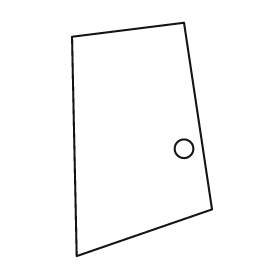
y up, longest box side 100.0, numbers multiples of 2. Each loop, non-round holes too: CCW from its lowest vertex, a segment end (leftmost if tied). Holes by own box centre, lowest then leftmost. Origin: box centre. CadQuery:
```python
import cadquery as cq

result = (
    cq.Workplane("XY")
    .moveTo(-28.0, -50.0)
    .lineTo(30.0, -30.0)
    .lineTo(18.0, 50.0)
    .lineTo(-30.0, 44.0)
    .close()
    .moveTo(18.0, -4.0)
    .circle(4.0)
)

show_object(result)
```